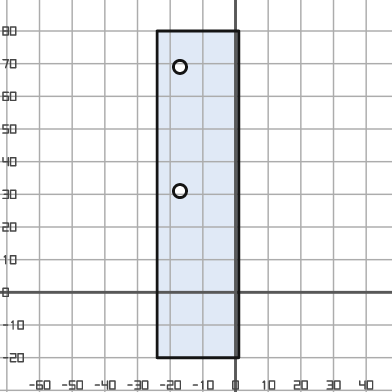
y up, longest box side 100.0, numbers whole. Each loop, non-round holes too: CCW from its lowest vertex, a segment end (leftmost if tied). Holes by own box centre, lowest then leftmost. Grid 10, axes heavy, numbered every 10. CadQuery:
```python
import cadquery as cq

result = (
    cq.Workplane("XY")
    .moveTo(-24.0, -20.0)
    .lineTo(1.0, -20.0)
    .lineTo(1.0, 80.0)
    .lineTo(-24.0, 80.0)
    .close()
    .moveTo(-17.0, 31.0)
    .circle(2.0)
    .moveTo(-17.0, 69.0)
    .circle(2.0)
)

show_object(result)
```